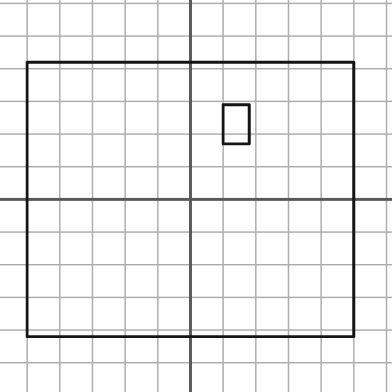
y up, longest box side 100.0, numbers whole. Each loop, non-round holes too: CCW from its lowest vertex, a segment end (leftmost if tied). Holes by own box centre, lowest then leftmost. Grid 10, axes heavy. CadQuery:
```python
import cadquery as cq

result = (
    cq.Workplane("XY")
    .moveTo(-50.0, -42.0)
    .lineTo(50.0, -42.0)
    .lineTo(50.0, 42.0)
    .lineTo(-50.0, 42.0)
    .close()
    .moveTo(10.0, 17.0)
    .lineTo(18.0, 17.0)
    .lineTo(18.0, 29.0)
    .lineTo(10.0, 29.0)
    .close()
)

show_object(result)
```